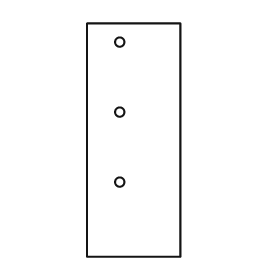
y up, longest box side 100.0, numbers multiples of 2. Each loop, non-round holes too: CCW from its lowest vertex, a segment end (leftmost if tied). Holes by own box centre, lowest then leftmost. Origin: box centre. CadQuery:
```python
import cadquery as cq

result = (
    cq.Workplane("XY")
    .moveTo(-20.0, -50.0)
    .lineTo(20.0, -50.0)
    .lineTo(20.0, 50.0)
    .lineTo(-20.0, 50.0)
    .close()
    .moveTo(-6.0, -18.0)
    .circle(2.0)
    .moveTo(-6.0, 12.0)
    .circle(2.0)
    .moveTo(-6.0, 42.0)
    .circle(2.0)
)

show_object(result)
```